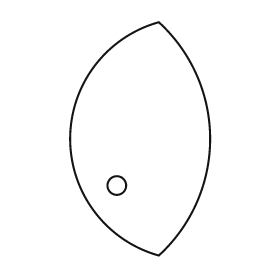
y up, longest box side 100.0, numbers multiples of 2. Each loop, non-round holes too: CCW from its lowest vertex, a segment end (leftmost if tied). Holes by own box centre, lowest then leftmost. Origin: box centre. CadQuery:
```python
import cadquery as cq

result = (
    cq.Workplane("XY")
    .moveTo(8.0, -50.0)
    .threePointArc((30.0, 0.0), (8.0, 50.0))
    .threePointArc((-30.0, 0.0), (8.0, -50.0))
    .close()
    .moveTo(-10.0, -20.0)
    .circle(4.0)
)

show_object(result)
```